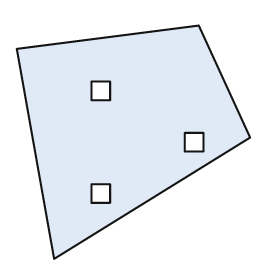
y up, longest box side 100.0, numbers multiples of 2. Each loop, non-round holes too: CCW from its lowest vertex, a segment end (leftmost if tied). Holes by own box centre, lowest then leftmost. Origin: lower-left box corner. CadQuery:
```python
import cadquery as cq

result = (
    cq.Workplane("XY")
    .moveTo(16.0, 0.0)
    .lineTo(100.0, 52.0)
    .lineTo(78.0, 100.0)
    .lineTo(0.0, 90.0)
    .close()
    .moveTo(32.0, 24.0)
    .lineTo(40.0, 24.0)
    .lineTo(40.0, 32.0)
    .lineTo(32.0, 32.0)
    .close()
    .moveTo(72.0, 46.0)
    .lineTo(80.0, 46.0)
    .lineTo(80.0, 54.0)
    .lineTo(72.0, 54.0)
    .close()
    .moveTo(32.0, 68.0)
    .lineTo(40.0, 68.0)
    .lineTo(40.0, 76.0)
    .lineTo(32.0, 76.0)
    .close()
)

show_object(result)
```